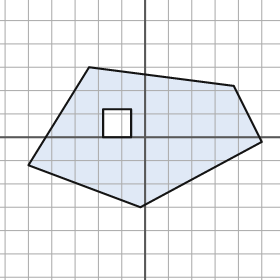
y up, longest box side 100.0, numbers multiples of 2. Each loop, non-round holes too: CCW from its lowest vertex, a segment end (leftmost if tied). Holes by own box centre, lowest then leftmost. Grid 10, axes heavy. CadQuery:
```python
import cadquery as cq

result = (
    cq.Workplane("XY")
    .moveTo(-2.0, -30.0)
    .lineTo(50.0, -2.0)
    .lineTo(38.0, 22.0)
    .lineTo(-24.0, 30.0)
    .lineTo(-50.0, -12.0)
    .close()
    .moveTo(-18.0, 0.0)
    .lineTo(-6.0, 0.0)
    .lineTo(-6.0, 12.0)
    .lineTo(-18.0, 12.0)
    .close()
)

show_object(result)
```